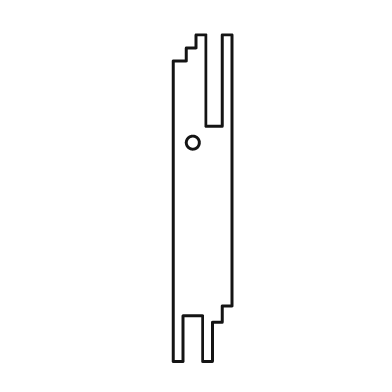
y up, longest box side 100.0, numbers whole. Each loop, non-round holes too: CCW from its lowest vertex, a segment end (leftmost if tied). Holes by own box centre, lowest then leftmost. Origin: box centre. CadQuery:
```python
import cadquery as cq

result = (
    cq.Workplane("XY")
    .moveTo(-9.0, -50.0)
    .lineTo(-6.0, -50.0)
    .lineTo(-6.0, -36.0)
    .lineTo(0.0, -36.0)
    .lineTo(0.0, -50.0)
    .lineTo(3.0, -50.0)
    .lineTo(3.0, -38.0)
    .lineTo(6.0, -38.0)
    .lineTo(6.0, -33.0)
    .lineTo(9.0, -33.0)
    .lineTo(9.0, 50.0)
    .lineTo(6.0, 50.0)
    .lineTo(6.0, 22.0)
    .lineTo(1.0, 22.0)
    .lineTo(1.0, 50.0)
    .lineTo(-2.0, 50.0)
    .lineTo(-2.0, 46.0)
    .lineTo(-5.0, 46.0)
    .lineTo(-5.0, 42.0)
    .lineTo(-9.0, 42.0)
    .close()
    .moveTo(-3.0, 17.0)
    .circle(2.0)
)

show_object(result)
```